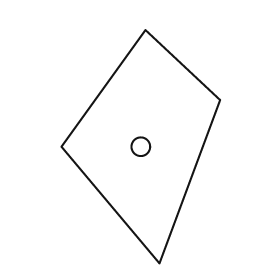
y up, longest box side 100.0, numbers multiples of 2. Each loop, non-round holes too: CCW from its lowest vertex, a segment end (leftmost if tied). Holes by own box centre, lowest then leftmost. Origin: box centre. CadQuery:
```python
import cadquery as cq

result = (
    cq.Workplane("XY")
    .moveTo(8.0, -50.0)
    .lineTo(34.0, 20.0)
    .lineTo(2.0, 50.0)
    .lineTo(-34.0, 0.0)
    .close()
    .moveTo(0.0, 0.0)
    .circle(4.0)
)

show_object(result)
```